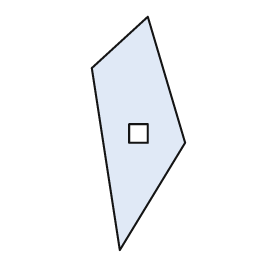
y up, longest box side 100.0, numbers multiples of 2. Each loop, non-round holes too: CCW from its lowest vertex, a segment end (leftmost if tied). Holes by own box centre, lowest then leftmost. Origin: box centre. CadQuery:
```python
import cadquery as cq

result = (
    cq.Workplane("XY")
    .moveTo(-8.0, -50.0)
    .lineTo(20.0, -4.0)
    .lineTo(4.0, 50.0)
    .lineTo(-20.0, 28.0)
    .close()
    .moveTo(-4.0, -4.0)
    .lineTo(4.0, -4.0)
    .lineTo(4.0, 4.0)
    .lineTo(-4.0, 4.0)
    .close()
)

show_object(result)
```